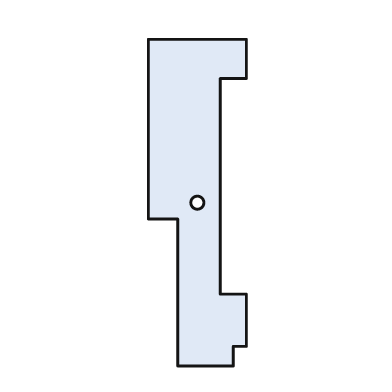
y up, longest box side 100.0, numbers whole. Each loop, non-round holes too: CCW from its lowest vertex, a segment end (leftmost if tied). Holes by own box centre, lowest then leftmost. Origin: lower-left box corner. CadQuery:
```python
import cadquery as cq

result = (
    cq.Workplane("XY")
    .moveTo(9.0, 0.0)
    .lineTo(26.0, 0.0)
    .lineTo(26.0, 6.0)
    .lineTo(30.0, 6.0)
    .lineTo(30.0, 22.0)
    .lineTo(22.0, 22.0)
    .lineTo(22.0, 88.0)
    .lineTo(30.0, 88.0)
    .lineTo(30.0, 100.0)
    .lineTo(0.0, 100.0)
    .lineTo(0.0, 45.0)
    .lineTo(9.0, 45.0)
    .close()
    .moveTo(15.0, 50.0)
    .circle(2.0)
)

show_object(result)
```